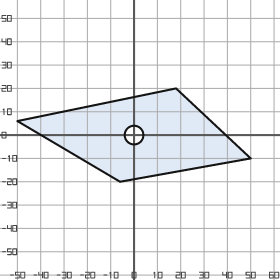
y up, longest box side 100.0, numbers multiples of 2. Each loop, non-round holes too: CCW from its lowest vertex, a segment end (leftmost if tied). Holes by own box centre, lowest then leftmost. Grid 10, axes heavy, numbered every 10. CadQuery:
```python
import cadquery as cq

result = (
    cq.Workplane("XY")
    .moveTo(-6.0, -20.0)
    .lineTo(50.0, -10.0)
    .lineTo(18.0, 20.0)
    .lineTo(-50.0, 6.0)
    .close()
    .moveTo(0.0, 0.0)
    .circle(4.0)
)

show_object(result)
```